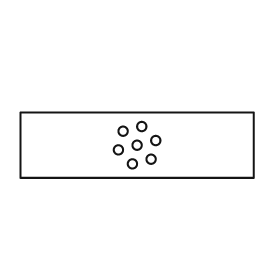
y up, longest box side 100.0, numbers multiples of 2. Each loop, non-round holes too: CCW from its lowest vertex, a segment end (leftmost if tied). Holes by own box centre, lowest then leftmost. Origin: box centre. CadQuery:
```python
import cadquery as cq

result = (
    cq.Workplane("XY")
    .moveTo(-50.0, -14.0)
    .lineTo(50.0, -14.0)
    .lineTo(50.0, 14.0)
    .lineTo(-50.0, 14.0)
    .close()
    .moveTo(-2.0, -8.0)
    .circle(2.0)
    .moveTo(6.0, -6.0)
    .circle(2.0)
    .moveTo(-8.0, -2.0)
    .circle(2.0)
    .moveTo(0.0, 0.0)
    .circle(2.0)
    .moveTo(8.0, 2.0)
    .circle(2.0)
    .moveTo(-6.0, 6.0)
    .circle(2.0)
    .moveTo(2.0, 8.0)
    .circle(2.0)
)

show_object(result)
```